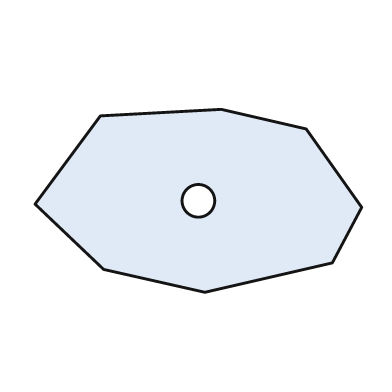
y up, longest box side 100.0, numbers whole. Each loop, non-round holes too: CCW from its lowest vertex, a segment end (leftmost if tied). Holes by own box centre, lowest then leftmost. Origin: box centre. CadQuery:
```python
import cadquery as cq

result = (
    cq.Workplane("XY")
    .moveTo(2.0, -28.0)
    .lineTo(41.0, -19.0)
    .lineTo(50.0, -2.0)
    .lineTo(33.0, 22.0)
    .lineTo(7.0, 28.0)
    .lineTo(-30.0, 26.0)
    .lineTo(-50.0, -1.0)
    .lineTo(-29.0, -21.0)
    .close()
    .moveTo(0.0, 0.0)
    .circle(5.0)
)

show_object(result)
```